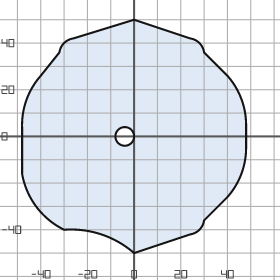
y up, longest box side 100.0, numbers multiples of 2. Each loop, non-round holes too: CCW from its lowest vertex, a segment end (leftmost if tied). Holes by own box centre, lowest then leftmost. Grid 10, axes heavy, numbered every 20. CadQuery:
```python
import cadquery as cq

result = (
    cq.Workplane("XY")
    .moveTo(0.0, -50.0)
    .lineTo(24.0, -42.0)
    .threePointArc((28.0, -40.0), (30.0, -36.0))
    .lineTo(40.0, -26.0)
    .threePointArc((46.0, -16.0), (48.0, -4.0))
    .lineTo(48.0, 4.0)
    .threePointArc((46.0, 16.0), (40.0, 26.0))
    .lineTo(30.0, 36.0)
    .threePointArc((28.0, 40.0), (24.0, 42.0))
    .lineTo(0.0, 50.0)
    .lineTo(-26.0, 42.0)
    .threePointArc((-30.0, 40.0), (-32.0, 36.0))
    .lineTo(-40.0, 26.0)
    .threePointArc((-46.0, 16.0), (-48.0, 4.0))
    .lineTo(-48.0, -16.0)
    .threePointArc((-42.0, -30.0), (-30.0, -40.0))
    .threePointArc((-14.0, -42.0), (0.0, -50.0))
    .close()
    .moveTo(-4.0, 0.0)
    .circle(4.0)
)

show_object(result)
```